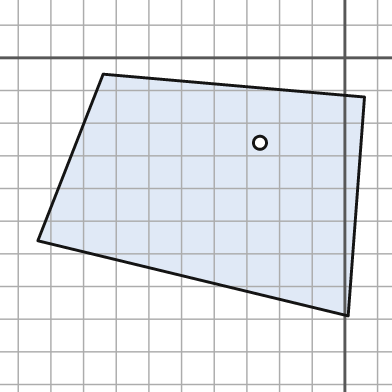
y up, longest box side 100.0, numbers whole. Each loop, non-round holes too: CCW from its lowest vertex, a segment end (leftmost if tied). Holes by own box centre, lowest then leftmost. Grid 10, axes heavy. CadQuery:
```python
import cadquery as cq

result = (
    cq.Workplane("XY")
    .moveTo(1.0, -79.0)
    .lineTo(6.0, -12.0)
    .lineTo(-74.0, -5.0)
    .lineTo(-94.0, -56.0)
    .close()
    .moveTo(-26.0, -26.0)
    .circle(2.0)
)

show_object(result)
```